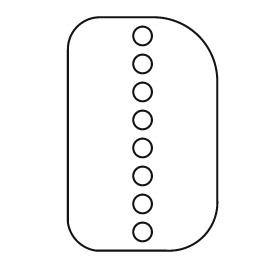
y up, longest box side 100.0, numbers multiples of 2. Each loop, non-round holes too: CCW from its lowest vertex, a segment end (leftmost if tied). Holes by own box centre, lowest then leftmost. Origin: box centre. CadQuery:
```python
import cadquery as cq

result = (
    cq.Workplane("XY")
    .moveTo(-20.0, -50.0)
    .lineTo(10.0, -50.0)
    .threePointArc((26.0, -44.0), (32.0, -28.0))
    .lineTo(32.0, 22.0)
    .threePointArc((24.0, 42.0), (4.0, 50.0))
    .lineTo(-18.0, 50.0)
    .threePointArc((-28.0, 46.0), (-32.0, 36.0))
    .lineTo(-32.0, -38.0)
    .threePointArc((-28.0, -46.0), (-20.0, -50.0))
    .close()
    .moveTo(0.0, -42.0)
    .circle(4.0)
    .moveTo(0.0, -30.0)
    .circle(4.0)
    .moveTo(0.0, -18.0)
    .circle(4.0)
    .moveTo(0.0, -6.0)
    .circle(4.0)
    .moveTo(0.0, 6.0)
    .circle(4.0)
    .moveTo(0.0, 18.0)
    .circle(4.0)
    .moveTo(0.0, 30.0)
    .circle(4.0)
    .moveTo(0.0, 42.0)
    .circle(4.0)
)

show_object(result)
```